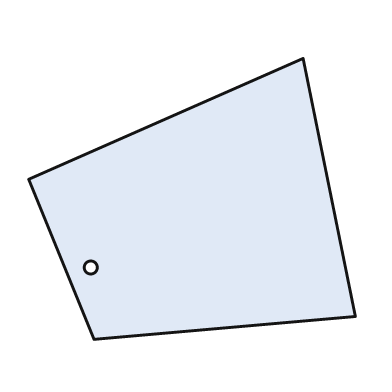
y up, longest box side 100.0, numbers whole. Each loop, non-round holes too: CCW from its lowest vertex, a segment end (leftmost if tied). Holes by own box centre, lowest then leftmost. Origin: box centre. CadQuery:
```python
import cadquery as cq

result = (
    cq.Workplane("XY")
    .moveTo(-30.0, -43.0)
    .lineTo(50.0, -36.0)
    .lineTo(34.0, 43.0)
    .lineTo(-50.0, 6.0)
    .close()
    .moveTo(-31.0, -21.0)
    .circle(2.0)
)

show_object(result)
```